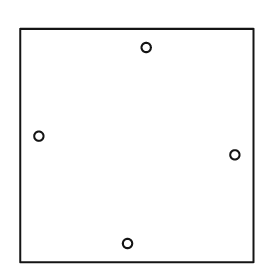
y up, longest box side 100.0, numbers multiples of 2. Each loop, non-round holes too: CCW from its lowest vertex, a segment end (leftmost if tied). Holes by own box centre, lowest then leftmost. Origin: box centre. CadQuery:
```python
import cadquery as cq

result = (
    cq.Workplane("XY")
    .moveTo(-50.0, -50.0)
    .lineTo(50.0, -50.0)
    .lineTo(50.0, 50.0)
    .lineTo(-50.0, 50.0)
    .close()
    .moveTo(-4.0, -42.0)
    .circle(2.0)
    .moveTo(42.0, -4.0)
    .circle(2.0)
    .moveTo(-42.0, 4.0)
    .circle(2.0)
    .moveTo(4.0, 42.0)
    .circle(2.0)
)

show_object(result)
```